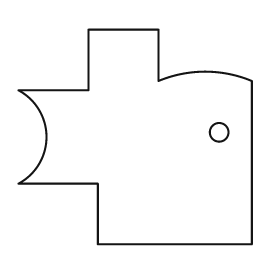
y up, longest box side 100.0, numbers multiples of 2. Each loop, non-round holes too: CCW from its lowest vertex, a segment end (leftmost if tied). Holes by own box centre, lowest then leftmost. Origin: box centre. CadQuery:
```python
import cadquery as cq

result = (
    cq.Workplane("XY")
    .moveTo(-16.0, -46.0)
    .lineTo(50.0, -46.0)
    .lineTo(50.0, 24.0)
    .threePointArc((30.0, 28.0), (10.0, 24.0))
    .lineTo(10.0, 46.0)
    .lineTo(-20.0, 46.0)
    .lineTo(-20.0, 20.0)
    .lineTo(-50.0, 20.0)
    .threePointArc((-38.0, 0.0), (-50.0, -20.0))
    .lineTo(-16.0, -20.0)
    .close()
    .moveTo(36.0, 2.0)
    .circle(4.0)
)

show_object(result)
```